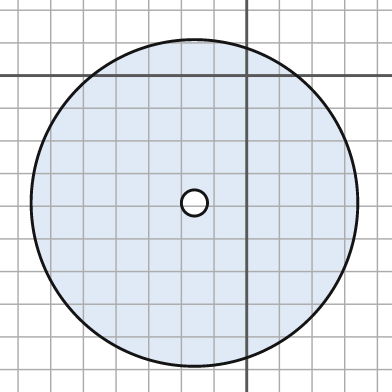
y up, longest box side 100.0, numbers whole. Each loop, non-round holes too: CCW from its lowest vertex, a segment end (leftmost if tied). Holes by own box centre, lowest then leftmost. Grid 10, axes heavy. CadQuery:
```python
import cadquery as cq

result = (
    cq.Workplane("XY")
    .moveTo(-16.0, -39.0)
    .circle(50.0)
    .moveTo(-16.0, -39.0)
    .circle(4.0)
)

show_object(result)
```